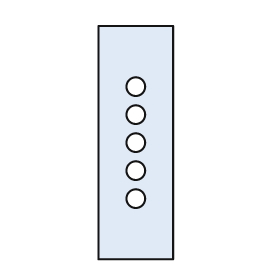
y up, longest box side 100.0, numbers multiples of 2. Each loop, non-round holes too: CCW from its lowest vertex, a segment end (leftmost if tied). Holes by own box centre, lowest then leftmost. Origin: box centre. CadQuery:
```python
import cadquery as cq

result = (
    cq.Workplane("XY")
    .moveTo(-16.0, -50.0)
    .lineTo(16.0, -50.0)
    .lineTo(16.0, 50.0)
    .lineTo(-16.0, 50.0)
    .close()
    .moveTo(0.0, -24.0)
    .circle(4.0)
    .moveTo(0.0, -12.0)
    .circle(4.0)
    .moveTo(0.0, 0.0)
    .circle(4.0)
    .moveTo(0.0, 12.0)
    .circle(4.0)
    .moveTo(0.0, 24.0)
    .circle(4.0)
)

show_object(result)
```